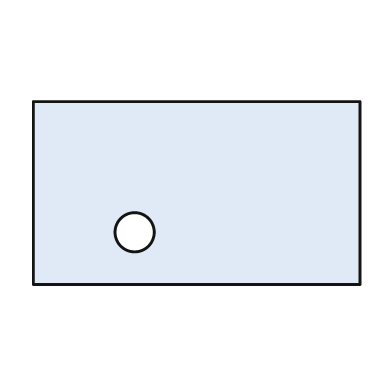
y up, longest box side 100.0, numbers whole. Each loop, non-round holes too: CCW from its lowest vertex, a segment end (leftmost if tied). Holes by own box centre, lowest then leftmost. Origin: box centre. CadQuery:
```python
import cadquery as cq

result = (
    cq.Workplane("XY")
    .moveTo(-50.0, -28.0)
    .lineTo(50.0, -28.0)
    .lineTo(50.0, 28.0)
    .lineTo(-50.0, 28.0)
    .close()
    .moveTo(-19.0, -12.0)
    .circle(6.0)
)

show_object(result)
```